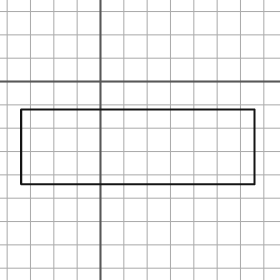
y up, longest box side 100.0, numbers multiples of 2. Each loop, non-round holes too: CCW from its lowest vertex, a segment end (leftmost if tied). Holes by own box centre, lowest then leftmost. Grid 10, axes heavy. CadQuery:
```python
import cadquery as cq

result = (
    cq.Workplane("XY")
    .moveTo(-34.0, -44.0)
    .lineTo(66.0, -44.0)
    .lineTo(66.0, -12.0)
    .lineTo(-34.0, -12.0)
    .close()
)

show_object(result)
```